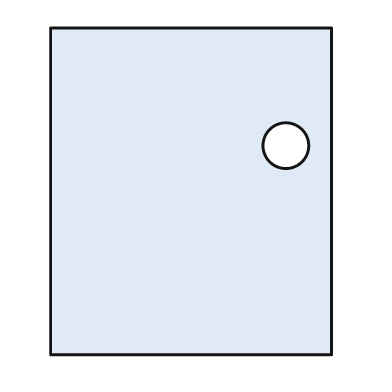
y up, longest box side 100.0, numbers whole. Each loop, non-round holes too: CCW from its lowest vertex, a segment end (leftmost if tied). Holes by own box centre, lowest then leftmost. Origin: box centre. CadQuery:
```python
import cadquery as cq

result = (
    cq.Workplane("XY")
    .moveTo(-43.0, -50.0)
    .lineTo(43.0, -50.0)
    .lineTo(43.0, 50.0)
    .lineTo(-43.0, 50.0)
    .close()
    .moveTo(29.0, 14.0)
    .circle(7.0)
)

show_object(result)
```